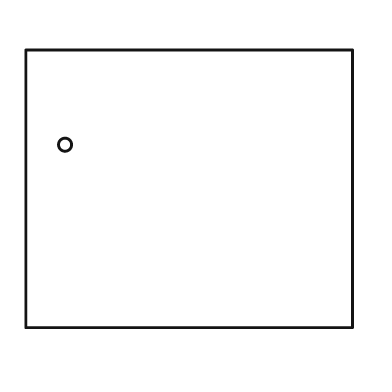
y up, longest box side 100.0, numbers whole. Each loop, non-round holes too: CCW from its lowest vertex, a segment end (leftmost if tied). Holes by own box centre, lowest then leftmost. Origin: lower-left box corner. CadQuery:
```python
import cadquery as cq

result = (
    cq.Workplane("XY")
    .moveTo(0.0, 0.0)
    .lineTo(100.0, 0.0)
    .lineTo(100.0, 85.0)
    .lineTo(0.0, 85.0)
    .close()
    .moveTo(12.0, 56.0)
    .circle(2.0)
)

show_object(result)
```